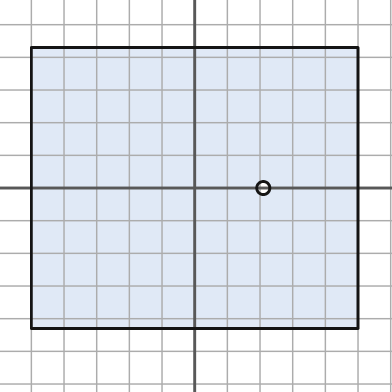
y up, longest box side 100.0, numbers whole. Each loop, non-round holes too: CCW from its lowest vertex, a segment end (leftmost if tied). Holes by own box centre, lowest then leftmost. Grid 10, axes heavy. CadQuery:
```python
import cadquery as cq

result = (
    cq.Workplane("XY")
    .moveTo(-50.0, -43.0)
    .lineTo(50.0, -43.0)
    .lineTo(50.0, 43.0)
    .lineTo(-50.0, 43.0)
    .close()
    .moveTo(21.0, 0.0)
    .circle(2.0)
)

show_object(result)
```